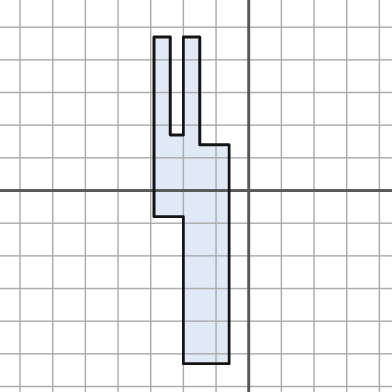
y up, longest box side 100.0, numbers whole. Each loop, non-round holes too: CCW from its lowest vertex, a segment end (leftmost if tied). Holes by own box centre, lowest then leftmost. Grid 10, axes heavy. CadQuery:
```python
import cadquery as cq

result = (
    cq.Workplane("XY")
    .moveTo(-20.0, -53.0)
    .lineTo(-6.0, -53.0)
    .lineTo(-6.0, 14.0)
    .lineTo(-15.0, 14.0)
    .lineTo(-15.0, 47.0)
    .lineTo(-20.0, 47.0)
    .lineTo(-20.0, 17.0)
    .lineTo(-24.0, 17.0)
    .lineTo(-24.0, 47.0)
    .lineTo(-29.0, 47.0)
    .lineTo(-29.0, -8.0)
    .lineTo(-20.0, -8.0)
    .close()
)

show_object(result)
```